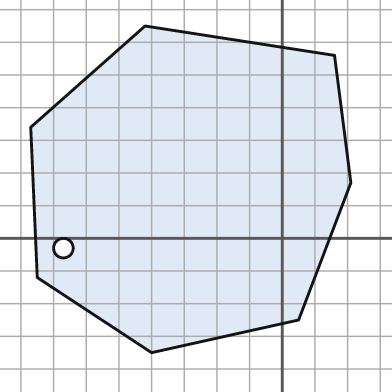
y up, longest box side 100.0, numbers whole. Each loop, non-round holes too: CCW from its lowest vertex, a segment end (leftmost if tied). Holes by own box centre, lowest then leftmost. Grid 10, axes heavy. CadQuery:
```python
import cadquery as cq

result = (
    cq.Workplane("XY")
    .moveTo(-40.0, -35.0)
    .lineTo(5.0, -25.0)
    .lineTo(21.0, 17.0)
    .lineTo(16.0, 56.0)
    .lineTo(-42.0, 65.0)
    .lineTo(-77.0, 34.0)
    .lineTo(-75.0, -12.0)
    .close()
    .moveTo(-67.0, -3.0)
    .circle(3.0)
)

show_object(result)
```